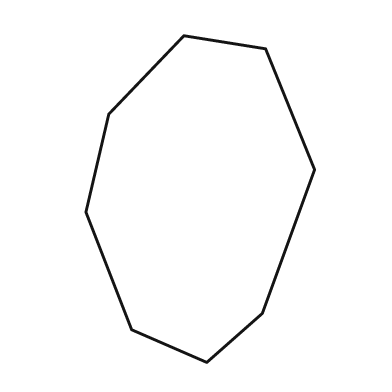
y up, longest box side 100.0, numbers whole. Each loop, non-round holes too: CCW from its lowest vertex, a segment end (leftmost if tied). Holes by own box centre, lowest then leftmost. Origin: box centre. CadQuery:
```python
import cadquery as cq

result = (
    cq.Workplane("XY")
    .moveTo(2.0, -50.0)
    .lineTo(19.0, -35.0)
    .lineTo(35.0, 9.0)
    .lineTo(20.0, 46.0)
    .lineTo(-5.0, 50.0)
    .lineTo(-28.0, 26.0)
    .lineTo(-35.0, -4.0)
    .lineTo(-21.0, -40.0)
    .close()
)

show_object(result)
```